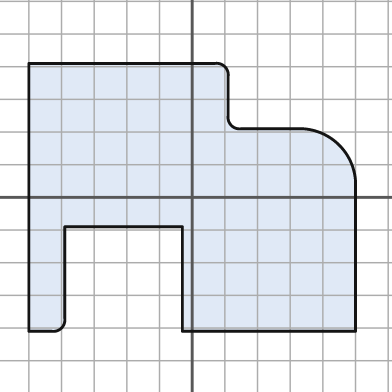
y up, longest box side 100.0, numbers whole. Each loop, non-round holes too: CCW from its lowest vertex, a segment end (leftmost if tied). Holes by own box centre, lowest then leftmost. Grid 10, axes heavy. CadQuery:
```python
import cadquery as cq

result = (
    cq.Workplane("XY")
    .moveTo(-50.0, -41.0)
    .lineTo(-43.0, -41.0)
    .threePointArc((-40.0, -40.0), (-39.0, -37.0))
    .lineTo(-39.0, -9.0)
    .lineTo(-3.0, -9.0)
    .lineTo(-3.0, -41.0)
    .lineTo(50.0, -41.0)
    .lineTo(50.0, 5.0)
    .threePointArc((45.0, 16.0), (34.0, 21.0))
    .lineTo(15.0, 21.0)
    .threePointArc((12.0, 22.0), (11.0, 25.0))
    .lineTo(11.0, 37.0)
    .threePointArc((10.0, 40.0), (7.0, 41.0))
    .lineTo(-50.0, 41.0)
    .close()
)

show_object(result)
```